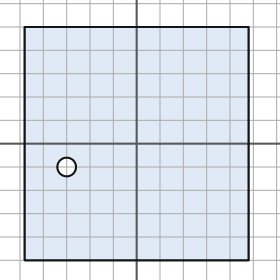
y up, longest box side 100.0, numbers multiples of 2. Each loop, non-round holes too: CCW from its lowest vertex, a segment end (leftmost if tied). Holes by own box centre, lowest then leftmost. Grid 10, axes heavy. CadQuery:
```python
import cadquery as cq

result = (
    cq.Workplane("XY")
    .moveTo(-48.0, -50.0)
    .lineTo(48.0, -50.0)
    .lineTo(48.0, 50.0)
    .lineTo(-48.0, 50.0)
    .close()
    .moveTo(-30.0, -10.0)
    .circle(4.0)
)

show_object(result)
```